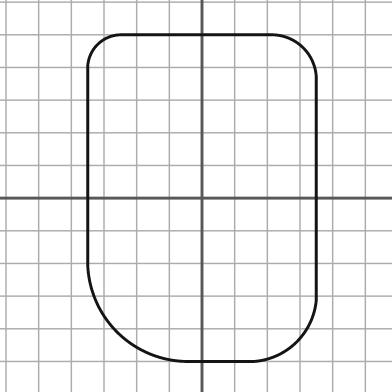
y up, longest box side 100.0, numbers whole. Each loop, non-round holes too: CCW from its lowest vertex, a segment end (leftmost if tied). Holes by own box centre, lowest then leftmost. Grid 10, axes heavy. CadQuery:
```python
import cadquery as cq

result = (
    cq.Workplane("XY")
    .moveTo(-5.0, -50.0)
    .lineTo(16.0, -50.0)
    .threePointArc((29.0, -44.0), (35.0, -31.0))
    .lineTo(35.0, 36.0)
    .threePointArc((31.0, 46.0), (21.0, 50.0))
    .lineTo(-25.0, 50.0)
    .threePointArc((-32.0, 47.0), (-35.0, 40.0))
    .lineTo(-35.0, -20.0)
    .threePointArc((-26.0, -41.0), (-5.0, -50.0))
    .close()
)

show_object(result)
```